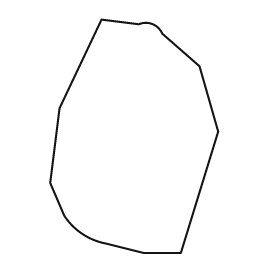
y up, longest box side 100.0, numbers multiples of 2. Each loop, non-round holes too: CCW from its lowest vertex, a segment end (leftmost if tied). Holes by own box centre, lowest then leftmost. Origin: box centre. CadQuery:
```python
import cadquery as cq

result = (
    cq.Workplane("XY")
    .moveTo(4.0, -50.0)
    .lineTo(20.0, -50.0)
    .lineTo(36.0, 2.0)
    .lineTo(28.0, 30.0)
    .lineTo(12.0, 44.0)
    .threePointArc((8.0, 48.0), (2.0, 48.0))
    .lineTo(-14.0, 50.0)
    .lineTo(-32.0, 12.0)
    .lineTo(-36.0, -20.0)
    .lineTo(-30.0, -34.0)
    .threePointArc((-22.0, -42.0), (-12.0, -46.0))
    .close()
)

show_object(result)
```